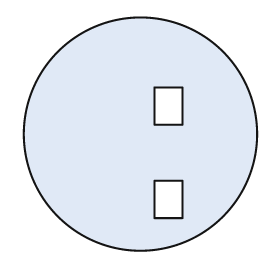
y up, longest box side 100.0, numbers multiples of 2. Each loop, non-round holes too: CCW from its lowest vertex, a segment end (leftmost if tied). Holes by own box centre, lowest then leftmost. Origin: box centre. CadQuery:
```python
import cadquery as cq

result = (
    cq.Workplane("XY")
    .moveTo(0.0, 0.0)
    .circle(50.0)
    .moveTo(6.0, -36.0)
    .lineTo(18.0, -36.0)
    .lineTo(18.0, -20.0)
    .lineTo(6.0, -20.0)
    .close()
    .moveTo(6.0, 4.0)
    .lineTo(18.0, 4.0)
    .lineTo(18.0, 20.0)
    .lineTo(6.0, 20.0)
    .close()
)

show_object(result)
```